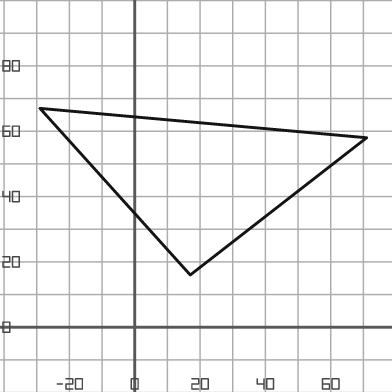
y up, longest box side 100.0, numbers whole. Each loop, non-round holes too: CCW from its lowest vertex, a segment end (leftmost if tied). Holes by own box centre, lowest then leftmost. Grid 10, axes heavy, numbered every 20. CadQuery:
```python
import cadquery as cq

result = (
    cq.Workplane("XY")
    .moveTo(17.0, 16.0)
    .lineTo(71.0, 58.0)
    .lineTo(-29.0, 67.0)
    .close()
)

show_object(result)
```